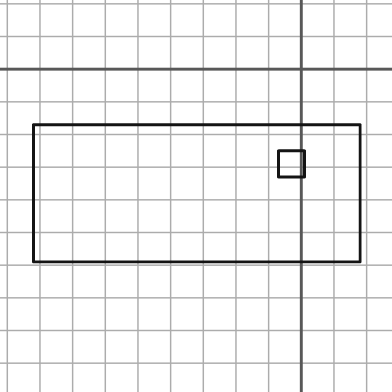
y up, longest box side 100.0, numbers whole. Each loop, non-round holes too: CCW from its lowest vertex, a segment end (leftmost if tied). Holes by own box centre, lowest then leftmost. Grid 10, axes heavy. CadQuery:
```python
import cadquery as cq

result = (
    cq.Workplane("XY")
    .moveTo(-82.0, -59.0)
    .lineTo(18.0, -59.0)
    .lineTo(18.0, -17.0)
    .lineTo(-82.0, -17.0)
    .close()
    .moveTo(-7.0, -33.0)
    .lineTo(1.0, -33.0)
    .lineTo(1.0, -25.0)
    .lineTo(-7.0, -25.0)
    .close()
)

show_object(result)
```